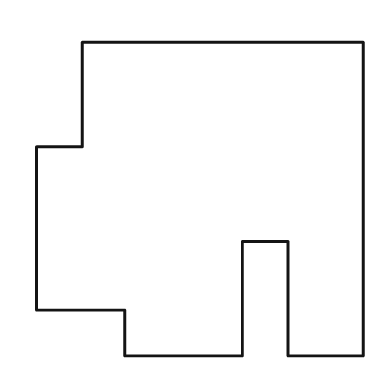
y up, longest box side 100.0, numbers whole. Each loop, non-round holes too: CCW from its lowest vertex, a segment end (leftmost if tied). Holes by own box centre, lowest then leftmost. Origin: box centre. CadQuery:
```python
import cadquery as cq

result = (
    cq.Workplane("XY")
    .moveTo(-23.0, -48.0)
    .lineTo(13.0, -48.0)
    .lineTo(13.0, -13.0)
    .lineTo(27.0, -13.0)
    .lineTo(27.0, -48.0)
    .lineTo(50.0, -48.0)
    .lineTo(50.0, 48.0)
    .lineTo(-36.0, 48.0)
    .lineTo(-36.0, 16.0)
    .lineTo(-50.0, 16.0)
    .lineTo(-50.0, -34.0)
    .lineTo(-23.0, -34.0)
    .close()
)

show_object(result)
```